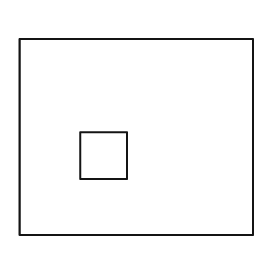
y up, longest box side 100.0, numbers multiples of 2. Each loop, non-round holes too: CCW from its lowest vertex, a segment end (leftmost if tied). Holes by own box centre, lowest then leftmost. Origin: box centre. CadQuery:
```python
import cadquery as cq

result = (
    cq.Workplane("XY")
    .moveTo(-50.0, -42.0)
    .lineTo(50.0, -42.0)
    .lineTo(50.0, 42.0)
    .lineTo(-50.0, 42.0)
    .close()
    .moveTo(-24.0, -18.0)
    .lineTo(-4.0, -18.0)
    .lineTo(-4.0, 2.0)
    .lineTo(-24.0, 2.0)
    .close()
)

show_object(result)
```